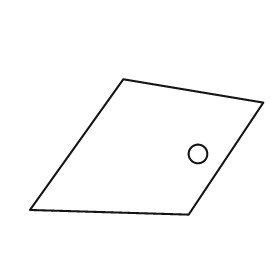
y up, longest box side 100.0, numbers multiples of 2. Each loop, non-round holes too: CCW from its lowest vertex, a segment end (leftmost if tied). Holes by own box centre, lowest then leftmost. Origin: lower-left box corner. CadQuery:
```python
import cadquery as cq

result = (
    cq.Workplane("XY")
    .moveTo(68.0, 0.0)
    .lineTo(100.0, 48.0)
    .lineTo(40.0, 58.0)
    .lineTo(0.0, 2.0)
    .close()
    .moveTo(72.0, 26.0)
    .circle(4.0)
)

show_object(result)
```